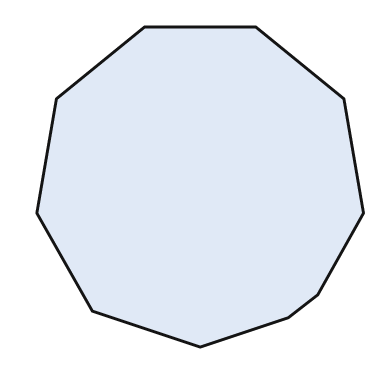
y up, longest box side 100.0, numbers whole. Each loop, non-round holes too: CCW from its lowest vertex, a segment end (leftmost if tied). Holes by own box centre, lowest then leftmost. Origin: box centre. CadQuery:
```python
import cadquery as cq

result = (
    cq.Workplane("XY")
    .moveTo(0.0, -49.0)
    .lineTo(27.0, -40.0)
    .lineTo(36.0, -33.0)
    .lineTo(50.0, -8.0)
    .lineTo(44.0, 27.0)
    .lineTo(17.0, 49.0)
    .lineTo(-17.0, 49.0)
    .lineTo(-44.0, 27.0)
    .lineTo(-50.0, -8.0)
    .lineTo(-33.0, -38.0)
    .close()
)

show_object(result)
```